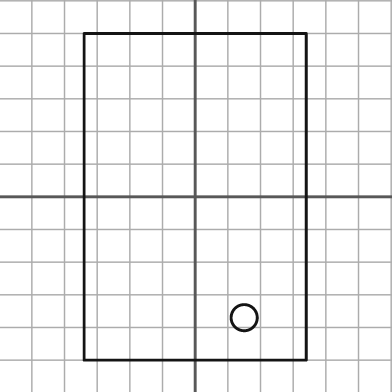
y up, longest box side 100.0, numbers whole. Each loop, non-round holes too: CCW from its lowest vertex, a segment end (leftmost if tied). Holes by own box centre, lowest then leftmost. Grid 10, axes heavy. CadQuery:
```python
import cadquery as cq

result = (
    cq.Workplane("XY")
    .moveTo(-34.0, -50.0)
    .lineTo(34.0, -50.0)
    .lineTo(34.0, 50.0)
    .lineTo(-34.0, 50.0)
    .close()
    .moveTo(15.0, -37.0)
    .circle(4.0)
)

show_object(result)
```